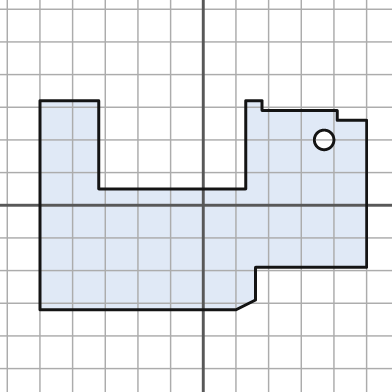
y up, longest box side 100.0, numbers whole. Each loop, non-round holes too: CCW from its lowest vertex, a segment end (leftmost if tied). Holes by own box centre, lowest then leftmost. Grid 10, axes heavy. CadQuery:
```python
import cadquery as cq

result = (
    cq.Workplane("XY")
    .moveTo(-50.0, -32.0)
    .lineTo(10.0, -32.0)
    .lineTo(16.0, -29.0)
    .lineTo(16.0, -19.0)
    .lineTo(50.0, -19.0)
    .lineTo(50.0, 26.0)
    .lineTo(41.0, 26.0)
    .lineTo(41.0, 29.0)
    .lineTo(18.0, 29.0)
    .lineTo(18.0, 32.0)
    .lineTo(13.0, 32.0)
    .lineTo(13.0, 5.0)
    .lineTo(-32.0, 5.0)
    .lineTo(-32.0, 32.0)
    .lineTo(-50.0, 32.0)
    .close()
    .moveTo(37.0, 20.0)
    .circle(3.0)
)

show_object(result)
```